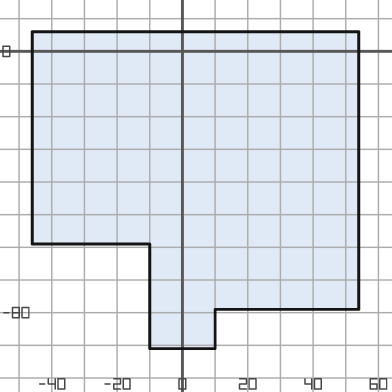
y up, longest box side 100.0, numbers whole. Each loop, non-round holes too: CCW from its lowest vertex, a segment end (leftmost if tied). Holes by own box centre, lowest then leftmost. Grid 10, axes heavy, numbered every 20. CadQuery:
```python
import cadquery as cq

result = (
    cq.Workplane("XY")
    .moveTo(-10.0, -91.0)
    .lineTo(10.0, -91.0)
    .lineTo(10.0, -79.0)
    .lineTo(54.0, -79.0)
    .lineTo(54.0, 6.0)
    .lineTo(-46.0, 6.0)
    .lineTo(-46.0, -59.0)
    .lineTo(-10.0, -59.0)
    .close()
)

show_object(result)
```